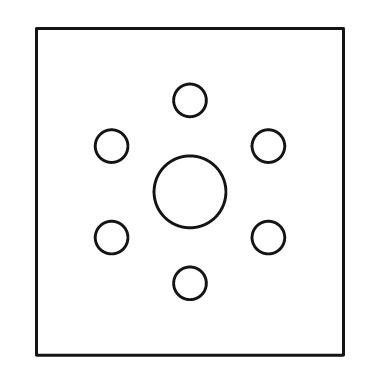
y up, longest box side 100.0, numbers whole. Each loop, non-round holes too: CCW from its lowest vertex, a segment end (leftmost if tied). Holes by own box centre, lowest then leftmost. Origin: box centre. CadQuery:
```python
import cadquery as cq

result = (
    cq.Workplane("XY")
    .moveTo(-47.0, -50.0)
    .lineTo(47.0, -50.0)
    .lineTo(47.0, 50.0)
    .lineTo(-47.0, 50.0)
    .close()
    .moveTo(0.0, -28.0)
    .circle(5.0)
    .moveTo(-24.0, -14.0)
    .circle(5.0)
    .moveTo(24.0, -14.0)
    .circle(5.0)
    .moveTo(0.0, 0.0)
    .circle(11.0)
    .moveTo(-24.0, 14.0)
    .circle(5.0)
    .moveTo(24.0, 14.0)
    .circle(5.0)
    .moveTo(0.0, 28.0)
    .circle(5.0)
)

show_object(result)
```